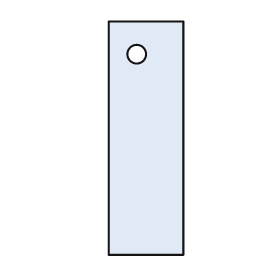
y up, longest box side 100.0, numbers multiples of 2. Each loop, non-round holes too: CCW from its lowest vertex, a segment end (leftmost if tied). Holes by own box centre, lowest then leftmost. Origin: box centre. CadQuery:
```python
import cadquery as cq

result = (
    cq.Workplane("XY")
    .moveTo(-16.0, -50.0)
    .lineTo(16.0, -50.0)
    .lineTo(16.0, 50.0)
    .lineTo(-16.0, 50.0)
    .close()
    .moveTo(-4.0, 36.0)
    .circle(4.0)
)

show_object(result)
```